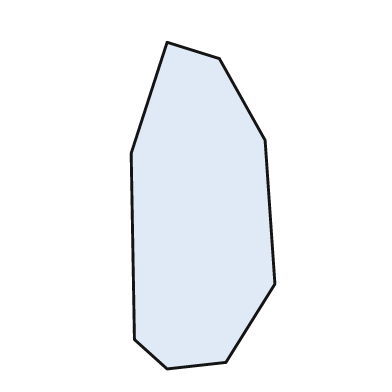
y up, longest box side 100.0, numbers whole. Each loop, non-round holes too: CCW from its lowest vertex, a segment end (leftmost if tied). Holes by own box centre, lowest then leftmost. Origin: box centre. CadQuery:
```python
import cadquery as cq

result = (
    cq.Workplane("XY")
    .moveTo(-11.0, -50.0)
    .lineTo(7.0, -48.0)
    .lineTo(22.0, -24.0)
    .lineTo(19.0, 20.0)
    .lineTo(5.0, 45.0)
    .lineTo(-11.0, 50.0)
    .lineTo(-22.0, 16.0)
    .lineTo(-21.0, -41.0)
    .close()
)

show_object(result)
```